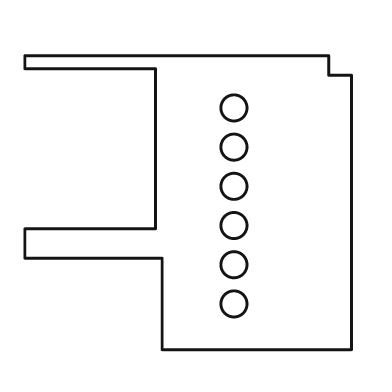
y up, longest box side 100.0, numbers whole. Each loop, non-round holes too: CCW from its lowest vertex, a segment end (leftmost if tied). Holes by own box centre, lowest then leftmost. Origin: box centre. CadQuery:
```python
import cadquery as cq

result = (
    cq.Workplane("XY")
    .moveTo(-8.0, -45.0)
    .lineTo(50.0, -45.0)
    .lineTo(50.0, 39.0)
    .lineTo(43.0, 39.0)
    .lineTo(43.0, 45.0)
    .lineTo(-50.0, 45.0)
    .lineTo(-50.0, 41.0)
    .lineTo(-10.0, 41.0)
    .lineTo(-10.0, -8.0)
    .lineTo(-50.0, -8.0)
    .lineTo(-50.0, -17.0)
    .lineTo(-8.0, -17.0)
    .close()
    .moveTo(14.0, -31.0)
    .circle(4.0)
    .moveTo(14.0, -19.0)
    .circle(4.0)
    .moveTo(14.0, -7.0)
    .circle(4.0)
    .moveTo(14.0, 5.0)
    .circle(4.0)
    .moveTo(14.0, 17.0)
    .circle(4.0)
    .moveTo(14.0, 29.0)
    .circle(4.0)
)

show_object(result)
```